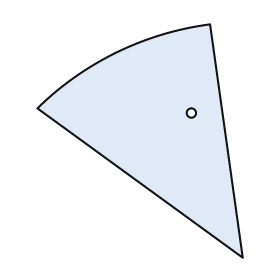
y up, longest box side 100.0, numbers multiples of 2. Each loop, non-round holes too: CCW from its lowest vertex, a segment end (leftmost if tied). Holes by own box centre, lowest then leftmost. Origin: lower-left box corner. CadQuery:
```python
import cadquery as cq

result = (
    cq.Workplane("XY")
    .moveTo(88.0, 0.0)
    .lineTo(74.0, 100.0)
    .threePointArc((34.0, 88.0), (0.0, 64.0))
    .close()
    .moveTo(66.0, 62.0)
    .circle(2.0)
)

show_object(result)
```